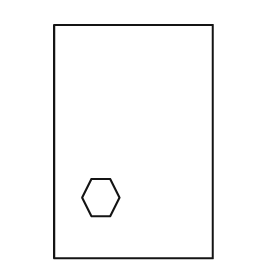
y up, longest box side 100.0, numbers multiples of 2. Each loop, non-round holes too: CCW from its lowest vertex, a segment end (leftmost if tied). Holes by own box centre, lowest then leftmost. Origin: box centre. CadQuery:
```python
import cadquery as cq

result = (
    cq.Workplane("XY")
    .moveTo(-34.0, -50.0)
    .lineTo(34.0, -50.0)
    .lineTo(34.0, 50.0)
    .lineTo(-34.0, 50.0)
    .close()
    .moveTo(-18.0, -32.0)
    .lineTo(-10.0, -32.0)
    .lineTo(-6.0, -24.0)
    .lineTo(-10.0, -16.0)
    .lineTo(-18.0, -16.0)
    .lineTo(-22.0, -24.0)
    .close()
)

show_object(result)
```